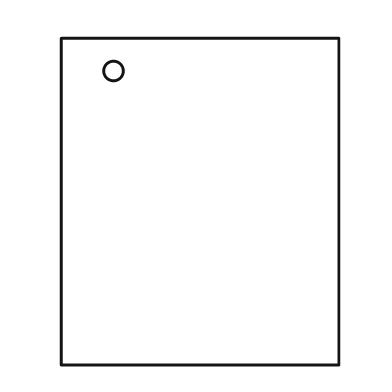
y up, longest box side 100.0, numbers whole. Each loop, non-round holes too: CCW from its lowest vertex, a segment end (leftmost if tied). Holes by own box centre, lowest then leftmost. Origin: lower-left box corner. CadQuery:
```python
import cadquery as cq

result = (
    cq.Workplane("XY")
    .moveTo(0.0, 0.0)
    .lineTo(85.0, 0.0)
    .lineTo(85.0, 100.0)
    .lineTo(0.0, 100.0)
    .close()
    .moveTo(16.0, 90.0)
    .circle(3.0)
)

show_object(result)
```